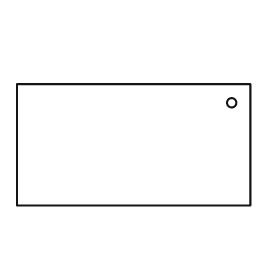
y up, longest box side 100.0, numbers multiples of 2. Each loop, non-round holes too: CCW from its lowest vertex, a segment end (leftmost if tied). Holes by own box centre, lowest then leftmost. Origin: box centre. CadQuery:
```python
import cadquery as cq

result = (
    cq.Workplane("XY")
    .moveTo(-50.0, -26.0)
    .lineTo(50.0, -26.0)
    .lineTo(50.0, 26.0)
    .lineTo(-50.0, 26.0)
    .close()
    .moveTo(42.0, 18.0)
    .circle(2.0)
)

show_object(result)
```